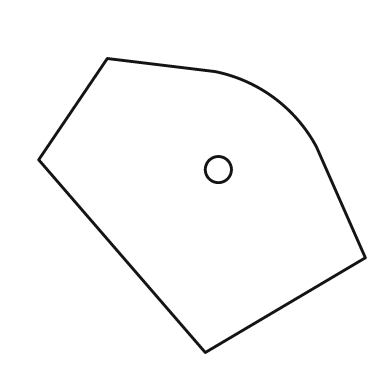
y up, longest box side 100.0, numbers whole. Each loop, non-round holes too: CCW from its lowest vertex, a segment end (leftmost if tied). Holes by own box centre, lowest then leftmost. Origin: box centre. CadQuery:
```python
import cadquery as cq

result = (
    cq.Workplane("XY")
    .moveTo(1.0, -45.0)
    .lineTo(50.0, -16.0)
    .lineTo(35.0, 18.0)
    .threePointArc((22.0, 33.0), (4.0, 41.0))
    .lineTo(-29.0, 45.0)
    .lineTo(-50.0, 14.0)
    .close()
    .moveTo(5.0, 11.0)
    .circle(4.0)
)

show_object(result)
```